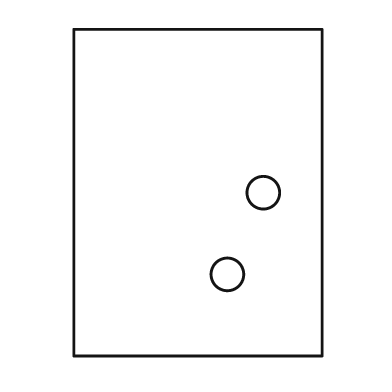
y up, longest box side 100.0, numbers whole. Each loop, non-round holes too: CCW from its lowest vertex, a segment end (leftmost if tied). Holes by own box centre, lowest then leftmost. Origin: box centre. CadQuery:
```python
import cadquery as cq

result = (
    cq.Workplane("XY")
    .moveTo(-38.0, -50.0)
    .lineTo(38.0, -50.0)
    .lineTo(38.0, 50.0)
    .lineTo(-38.0, 50.0)
    .close()
    .moveTo(9.0, -25.0)
    .circle(5.0)
    .moveTo(20.0, 0.0)
    .circle(5.0)
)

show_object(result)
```